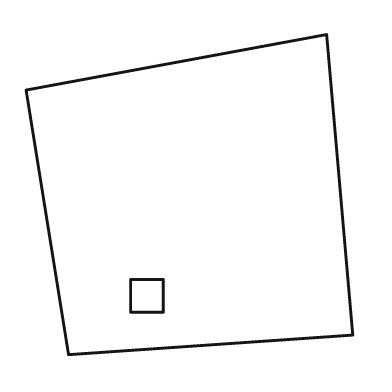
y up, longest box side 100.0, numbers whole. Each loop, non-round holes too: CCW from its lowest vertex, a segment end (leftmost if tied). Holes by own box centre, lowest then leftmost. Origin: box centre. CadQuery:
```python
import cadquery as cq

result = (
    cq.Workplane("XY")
    .moveTo(-37.0, -49.0)
    .lineTo(50.0, -43.0)
    .lineTo(42.0, 49.0)
    .lineTo(-50.0, 32.0)
    .close()
    .moveTo(-18.0, -36.0)
    .lineTo(-8.0, -36.0)
    .lineTo(-8.0, -26.0)
    .lineTo(-18.0, -26.0)
    .close()
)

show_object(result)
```